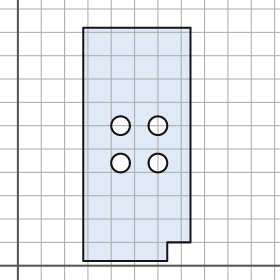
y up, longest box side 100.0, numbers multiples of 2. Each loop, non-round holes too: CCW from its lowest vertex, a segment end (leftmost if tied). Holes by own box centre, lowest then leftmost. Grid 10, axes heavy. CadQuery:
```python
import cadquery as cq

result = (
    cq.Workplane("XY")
    .moveTo(28.0, 2.0)
    .lineTo(64.0, 2.0)
    .lineTo(64.0, 10.0)
    .lineTo(74.0, 10.0)
    .lineTo(74.0, 102.0)
    .lineTo(28.0, 102.0)
    .close()
    .moveTo(44.0, 44.0)
    .circle(4.0)
    .moveTo(60.0, 44.0)
    .circle(4.0)
    .moveTo(44.0, 60.0)
    .circle(4.0)
    .moveTo(60.0, 60.0)
    .circle(4.0)
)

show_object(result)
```